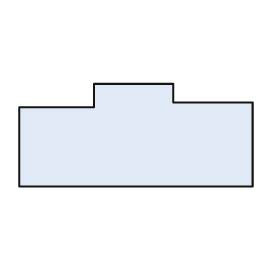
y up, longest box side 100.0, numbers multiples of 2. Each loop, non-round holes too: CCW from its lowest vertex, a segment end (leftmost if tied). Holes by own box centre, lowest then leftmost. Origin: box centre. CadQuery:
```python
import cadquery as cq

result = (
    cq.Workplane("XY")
    .moveTo(-50.0, -22.0)
    .lineTo(50.0, -22.0)
    .lineTo(50.0, 14.0)
    .lineTo(16.0, 14.0)
    .lineTo(16.0, 22.0)
    .lineTo(-18.0, 22.0)
    .lineTo(-18.0, 12.0)
    .lineTo(-50.0, 12.0)
    .close()
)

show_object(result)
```